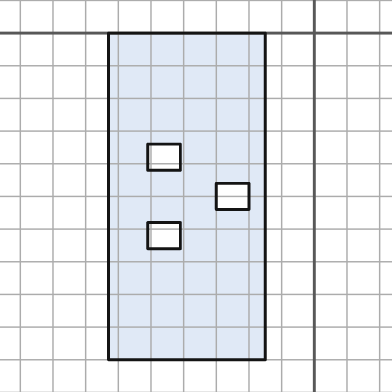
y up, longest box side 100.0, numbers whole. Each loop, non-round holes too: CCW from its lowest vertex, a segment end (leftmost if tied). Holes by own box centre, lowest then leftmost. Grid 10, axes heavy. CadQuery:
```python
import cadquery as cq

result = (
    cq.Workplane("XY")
    .moveTo(-63.0, -100.0)
    .lineTo(-15.0, -100.0)
    .lineTo(-15.0, 0.0)
    .lineTo(-63.0, 0.0)
    .close()
    .moveTo(-51.0, -66.0)
    .lineTo(-41.0, -66.0)
    .lineTo(-41.0, -58.0)
    .lineTo(-51.0, -58.0)
    .close()
    .moveTo(-30.0, -54.0)
    .lineTo(-20.0, -54.0)
    .lineTo(-20.0, -46.0)
    .lineTo(-30.0, -46.0)
    .close()
    .moveTo(-51.0, -42.0)
    .lineTo(-41.0, -42.0)
    .lineTo(-41.0, -34.0)
    .lineTo(-51.0, -34.0)
    .close()
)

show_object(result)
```